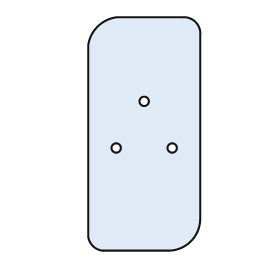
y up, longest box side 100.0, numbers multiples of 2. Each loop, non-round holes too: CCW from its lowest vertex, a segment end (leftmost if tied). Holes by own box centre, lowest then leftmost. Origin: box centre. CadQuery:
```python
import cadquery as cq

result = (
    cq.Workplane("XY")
    .moveTo(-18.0, -50.0)
    .lineTo(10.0, -50.0)
    .threePointArc((20.0, -46.0), (24.0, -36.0))
    .lineTo(24.0, 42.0)
    .threePointArc((22.0, 48.0), (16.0, 50.0))
    .lineTo(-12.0, 50.0)
    .threePointArc((-20.0, 46.0), (-24.0, 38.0))
    .lineTo(-24.0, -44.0)
    .threePointArc((-22.0, -48.0), (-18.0, -50.0))
    .close()
    .moveTo(-12.0, -6.0)
    .circle(2.0)
    .moveTo(12.0, -6.0)
    .circle(2.0)
    .moveTo(0.0, 14.0)
    .circle(2.0)
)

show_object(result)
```